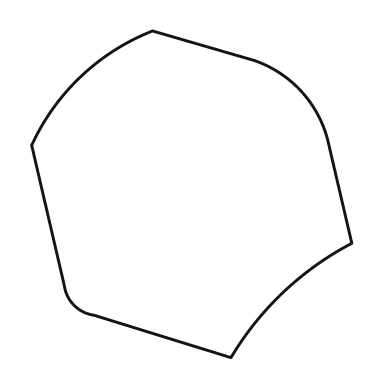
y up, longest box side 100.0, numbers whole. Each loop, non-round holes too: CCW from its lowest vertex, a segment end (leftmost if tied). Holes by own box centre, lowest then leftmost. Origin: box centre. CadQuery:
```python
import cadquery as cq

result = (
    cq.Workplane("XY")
    .moveTo(12.0, -50.0)
    .threePointArc((28.0, -30.0), (49.0, -15.0))
    .lineTo(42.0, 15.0)
    .threePointArc((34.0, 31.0), (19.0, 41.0))
    .lineTo(-12.0, 50.0)
    .threePointArc((-34.0, 36.0), (-49.0, 15.0))
    .lineTo(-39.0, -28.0)
    .threePointArc((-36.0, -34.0), (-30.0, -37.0))
    .close()
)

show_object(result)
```